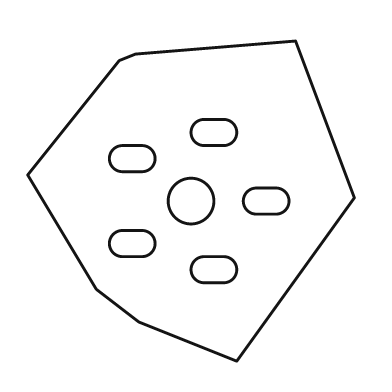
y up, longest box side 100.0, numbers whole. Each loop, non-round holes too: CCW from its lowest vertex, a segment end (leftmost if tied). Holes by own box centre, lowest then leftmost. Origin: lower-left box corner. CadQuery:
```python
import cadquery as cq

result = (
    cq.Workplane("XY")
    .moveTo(64.0, 0.0)
    .lineTo(100.0, 50.0)
    .lineTo(82.0, 98.0)
    .lineTo(33.0, 94.0)
    .lineTo(28.0, 92.0)
    .lineTo(0.0, 57.0)
    .lineTo(21.0, 22.0)
    .lineTo(34.0, 12.0)
    .close()
    .moveTo(54.0, 24.0)
    .lineTo(60.0, 24.0)
    .threePointArc((64.0, 28.0), (60.0, 32.0))
    .lineTo(54.0, 32.0)
    .threePointArc((50.0, 28.0), (54.0, 24.0))
    .close()
    .moveTo(29.0, 32.0)
    .lineTo(35.0, 32.0)
    .threePointArc((39.0, 36.0), (35.0, 40.0))
    .lineTo(29.0, 40.0)
    .threePointArc((25.0, 36.0), (29.0, 32.0))
    .close()
    .moveTo(50.0, 49.0)
    .circle(7.0)
    .moveTo(70.0, 45.0)
    .lineTo(76.0, 45.0)
    .threePointArc((80.0, 49.0), (76.0, 53.0))
    .lineTo(70.0, 53.0)
    .threePointArc((66.0, 49.0), (70.0, 45.0))
    .close()
    .moveTo(29.0, 58.0)
    .lineTo(35.0, 58.0)
    .threePointArc((39.0, 62.0), (35.0, 66.0))
    .lineTo(29.0, 66.0)
    .threePointArc((25.0, 62.0), (29.0, 58.0))
    .close()
    .moveTo(54.0, 66.0)
    .lineTo(60.0, 66.0)
    .threePointArc((64.0, 70.0), (60.0, 74.0))
    .lineTo(54.0, 74.0)
    .threePointArc((50.0, 70.0), (54.0, 66.0))
    .close()
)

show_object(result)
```